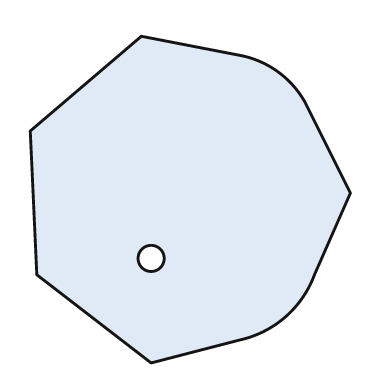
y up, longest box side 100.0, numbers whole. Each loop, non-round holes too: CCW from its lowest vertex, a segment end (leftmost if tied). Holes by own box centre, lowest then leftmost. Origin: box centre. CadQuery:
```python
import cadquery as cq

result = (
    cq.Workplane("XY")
    .moveTo(-12.0, -50.0)
    .lineTo(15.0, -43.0)
    .threePointArc((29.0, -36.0), (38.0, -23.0))
    .lineTo(49.0, 2.0)
    .lineTo(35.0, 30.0)
    .threePointArc((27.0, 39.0), (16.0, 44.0))
    .lineTo(-15.0, 50.0)
    .lineTo(-49.0, 21.0)
    .lineTo(-47.0, -23.0)
    .close()
    .moveTo(-12.0, -18.0)
    .circle(4.0)
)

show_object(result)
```